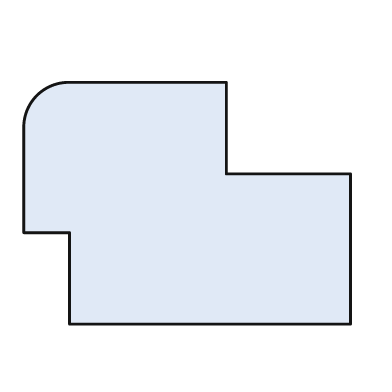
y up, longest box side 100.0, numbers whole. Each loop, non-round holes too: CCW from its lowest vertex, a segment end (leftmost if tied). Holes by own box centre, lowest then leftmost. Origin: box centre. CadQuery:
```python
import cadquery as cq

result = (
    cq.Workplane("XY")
    .moveTo(-36.0, -37.0)
    .lineTo(50.0, -37.0)
    .lineTo(50.0, 9.0)
    .lineTo(12.0, 9.0)
    .lineTo(12.0, 37.0)
    .lineTo(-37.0, 37.0)
    .threePointArc((-46.0, 33.0), (-50.0, 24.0))
    .lineTo(-50.0, -9.0)
    .lineTo(-36.0, -9.0)
    .close()
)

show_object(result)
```